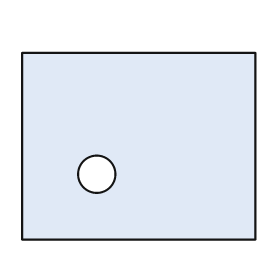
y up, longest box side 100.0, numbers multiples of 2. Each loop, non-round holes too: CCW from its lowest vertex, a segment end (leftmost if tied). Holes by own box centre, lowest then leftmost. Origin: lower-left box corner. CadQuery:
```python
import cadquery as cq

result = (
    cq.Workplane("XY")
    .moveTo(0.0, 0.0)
    .lineTo(100.0, 0.0)
    .lineTo(100.0, 80.0)
    .lineTo(0.0, 80.0)
    .close()
    .moveTo(32.0, 28.0)
    .circle(8.0)
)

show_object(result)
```